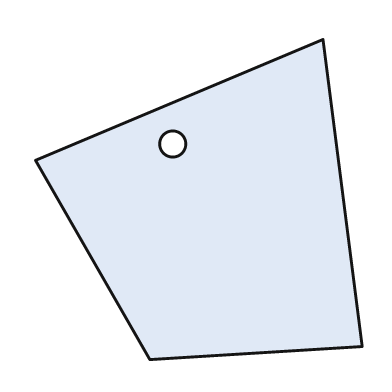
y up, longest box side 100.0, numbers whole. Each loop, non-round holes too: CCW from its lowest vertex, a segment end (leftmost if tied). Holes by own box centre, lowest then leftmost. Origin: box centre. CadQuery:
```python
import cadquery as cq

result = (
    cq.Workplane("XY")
    .moveTo(-15.0, -49.0)
    .lineTo(50.0, -45.0)
    .lineTo(38.0, 49.0)
    .lineTo(-50.0, 12.0)
    .close()
    .moveTo(-8.0, 17.0)
    .circle(4.0)
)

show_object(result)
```